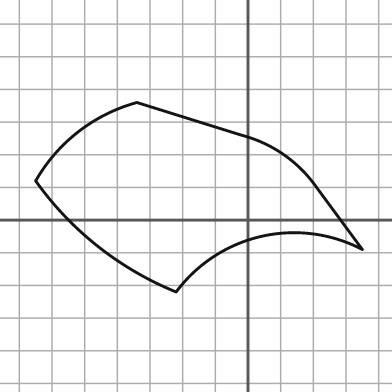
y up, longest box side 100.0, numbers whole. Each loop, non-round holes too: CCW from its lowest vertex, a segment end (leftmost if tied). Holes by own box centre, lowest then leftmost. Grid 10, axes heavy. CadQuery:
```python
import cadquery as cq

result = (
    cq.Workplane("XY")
    .moveTo(-22.0, -22.0)
    .threePointArc((4.0, -5.0), (35.0, -9.0))
    .lineTo(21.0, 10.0)
    .threePointArc((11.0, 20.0), (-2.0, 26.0))
    .lineTo(-34.0, 36.0)
    .threePointArc((-52.0, 27.0), (-65.0, 12.0))
    .threePointArc((-46.0, -8.0), (-22.0, -22.0))
    .close()
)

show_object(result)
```